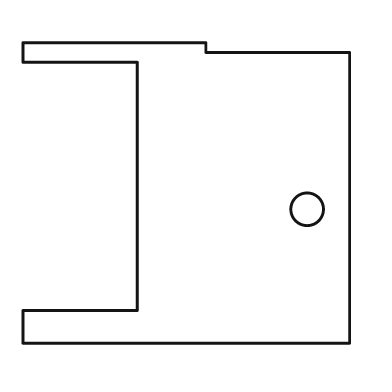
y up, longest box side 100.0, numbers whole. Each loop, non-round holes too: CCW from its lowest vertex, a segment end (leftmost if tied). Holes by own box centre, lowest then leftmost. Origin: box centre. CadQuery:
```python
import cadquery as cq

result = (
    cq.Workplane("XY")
    .moveTo(-50.0, -46.0)
    .lineTo(50.0, -46.0)
    .lineTo(50.0, 43.0)
    .lineTo(6.0, 43.0)
    .lineTo(6.0, 46.0)
    .lineTo(-50.0, 46.0)
    .lineTo(-50.0, 40.0)
    .lineTo(-15.0, 40.0)
    .lineTo(-15.0, -36.0)
    .lineTo(-50.0, -36.0)
    .close()
    .moveTo(37.0, -5.0)
    .circle(5.0)
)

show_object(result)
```